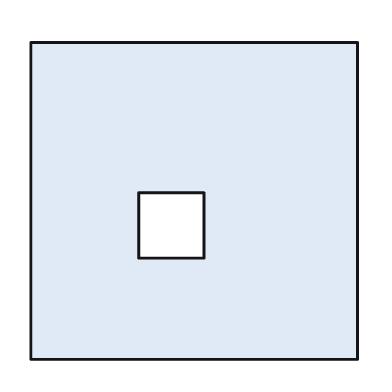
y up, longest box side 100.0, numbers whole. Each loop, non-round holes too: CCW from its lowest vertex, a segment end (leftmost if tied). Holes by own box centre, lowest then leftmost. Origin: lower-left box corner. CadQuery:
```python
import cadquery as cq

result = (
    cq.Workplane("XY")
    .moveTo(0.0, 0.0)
    .lineTo(100.0, 0.0)
    .lineTo(100.0, 97.0)
    .lineTo(0.0, 97.0)
    .close()
    .moveTo(33.0, 31.0)
    .lineTo(53.0, 31.0)
    .lineTo(53.0, 51.0)
    .lineTo(33.0, 51.0)
    .close()
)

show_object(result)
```